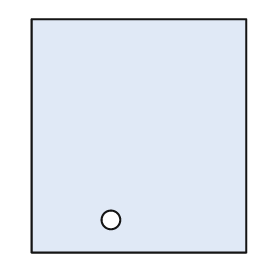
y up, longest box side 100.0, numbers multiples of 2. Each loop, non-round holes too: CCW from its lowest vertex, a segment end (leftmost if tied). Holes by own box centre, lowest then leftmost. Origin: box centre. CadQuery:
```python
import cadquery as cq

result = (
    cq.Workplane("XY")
    .moveTo(-46.0, -50.0)
    .lineTo(46.0, -50.0)
    .lineTo(46.0, 50.0)
    .lineTo(-46.0, 50.0)
    .close()
    .moveTo(-12.0, -36.0)
    .circle(4.0)
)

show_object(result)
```